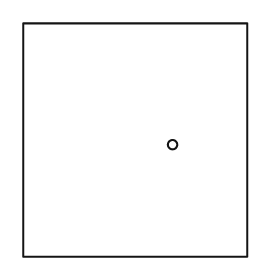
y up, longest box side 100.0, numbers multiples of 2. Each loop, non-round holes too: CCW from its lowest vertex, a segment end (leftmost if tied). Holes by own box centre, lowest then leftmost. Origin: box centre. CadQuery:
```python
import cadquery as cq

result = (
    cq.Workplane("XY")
    .moveTo(-48.0, -50.0)
    .lineTo(48.0, -50.0)
    .lineTo(48.0, 50.0)
    .lineTo(-48.0, 50.0)
    .close()
    .moveTo(16.0, -2.0)
    .circle(2.0)
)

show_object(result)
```